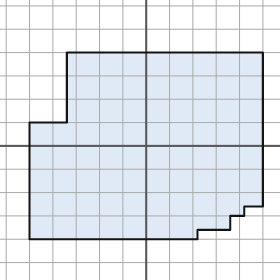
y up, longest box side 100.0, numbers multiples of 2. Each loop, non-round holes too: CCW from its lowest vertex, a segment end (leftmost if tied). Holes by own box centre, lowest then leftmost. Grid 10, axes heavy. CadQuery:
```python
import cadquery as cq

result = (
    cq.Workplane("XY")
    .moveTo(-50.0, -40.0)
    .lineTo(22.0, -40.0)
    .lineTo(22.0, -36.0)
    .lineTo(36.0, -36.0)
    .lineTo(36.0, -30.0)
    .lineTo(42.0, -30.0)
    .lineTo(42.0, -26.0)
    .lineTo(50.0, -26.0)
    .lineTo(50.0, 40.0)
    .lineTo(-34.0, 40.0)
    .lineTo(-34.0, 10.0)
    .lineTo(-50.0, 10.0)
    .close()
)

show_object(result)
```